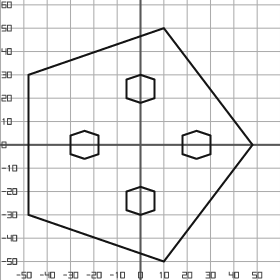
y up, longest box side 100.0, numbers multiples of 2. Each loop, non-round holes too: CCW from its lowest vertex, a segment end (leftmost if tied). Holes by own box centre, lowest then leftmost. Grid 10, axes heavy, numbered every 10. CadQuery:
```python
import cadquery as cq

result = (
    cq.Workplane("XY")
    .moveTo(10.0, -50.0)
    .lineTo(48.0, 0.0)
    .lineTo(10.0, 50.0)
    .lineTo(-48.0, 30.0)
    .lineTo(-48.0, -30.0)
    .close()
    .moveTo(0.0, -30.0)
    .lineTo(6.0, -28.0)
    .lineTo(6.0, -20.0)
    .lineTo(0.0, -18.0)
    .lineTo(-6.0, -20.0)
    .lineTo(-6.0, -28.0)
    .close()
    .moveTo(-24.0, -6.0)
    .lineTo(-18.0, -4.0)
    .lineTo(-18.0, 4.0)
    .lineTo(-24.0, 6.0)
    .lineTo(-30.0, 4.0)
    .lineTo(-30.0, -4.0)
    .close()
    .moveTo(24.0, -6.0)
    .lineTo(30.0, -4.0)
    .lineTo(30.0, 4.0)
    .lineTo(24.0, 6.0)
    .lineTo(18.0, 4.0)
    .lineTo(18.0, -4.0)
    .close()
    .moveTo(0.0, 18.0)
    .lineTo(6.0, 20.0)
    .lineTo(6.0, 28.0)
    .lineTo(0.0, 30.0)
    .lineTo(-6.0, 28.0)
    .lineTo(-6.0, 20.0)
    .close()
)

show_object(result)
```